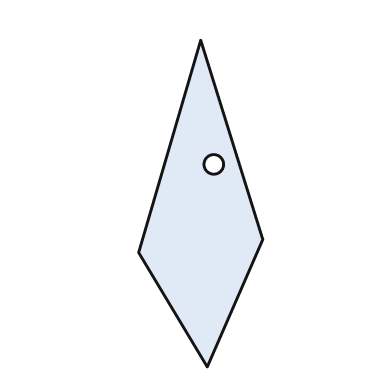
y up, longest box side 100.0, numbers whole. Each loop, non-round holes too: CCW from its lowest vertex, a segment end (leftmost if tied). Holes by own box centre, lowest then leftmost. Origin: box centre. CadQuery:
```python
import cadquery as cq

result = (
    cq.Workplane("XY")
    .moveTo(2.0, -50.0)
    .lineTo(19.0, -11.0)
    .lineTo(0.0, 50.0)
    .lineTo(-19.0, -15.0)
    .close()
    .moveTo(4.0, 12.0)
    .circle(3.0)
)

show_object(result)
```